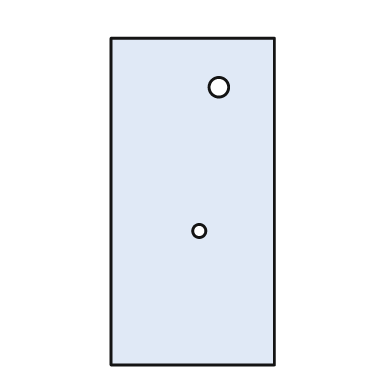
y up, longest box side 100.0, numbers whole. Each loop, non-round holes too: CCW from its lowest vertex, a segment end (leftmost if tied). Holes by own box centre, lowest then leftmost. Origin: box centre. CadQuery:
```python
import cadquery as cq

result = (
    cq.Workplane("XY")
    .moveTo(-25.0, -50.0)
    .lineTo(25.0, -50.0)
    .lineTo(25.0, 50.0)
    .lineTo(-25.0, 50.0)
    .close()
    .moveTo(2.0, -9.0)
    .circle(2.0)
    .moveTo(8.0, 35.0)
    .circle(3.0)
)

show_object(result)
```